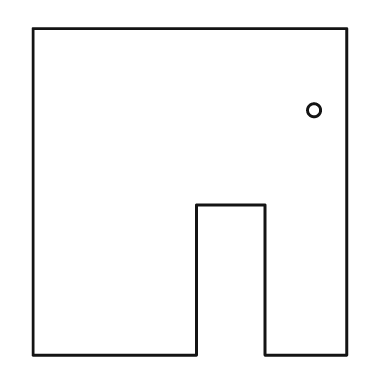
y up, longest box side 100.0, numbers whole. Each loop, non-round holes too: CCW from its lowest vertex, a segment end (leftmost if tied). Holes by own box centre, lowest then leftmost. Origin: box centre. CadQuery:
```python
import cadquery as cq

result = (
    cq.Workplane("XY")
    .moveTo(-48.0, -50.0)
    .lineTo(2.0, -50.0)
    .lineTo(2.0, -4.0)
    .lineTo(23.0, -4.0)
    .lineTo(23.0, -50.0)
    .lineTo(48.0, -50.0)
    .lineTo(48.0, 50.0)
    .lineTo(-48.0, 50.0)
    .close()
    .moveTo(38.0, 25.0)
    .circle(2.0)
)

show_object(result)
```